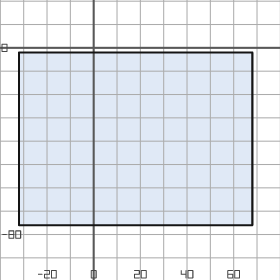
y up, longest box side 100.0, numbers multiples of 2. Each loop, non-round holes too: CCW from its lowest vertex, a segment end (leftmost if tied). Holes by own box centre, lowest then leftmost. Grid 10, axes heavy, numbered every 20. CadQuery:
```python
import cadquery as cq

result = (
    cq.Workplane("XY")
    .moveTo(-32.0, -76.0)
    .lineTo(68.0, -76.0)
    .lineTo(68.0, -2.0)
    .lineTo(-32.0, -2.0)
    .close()
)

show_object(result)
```